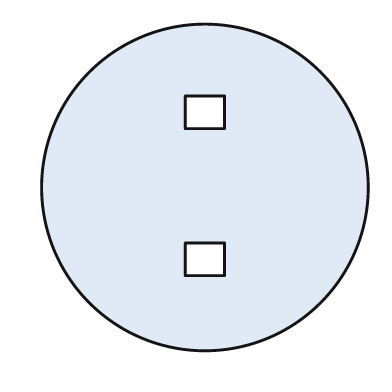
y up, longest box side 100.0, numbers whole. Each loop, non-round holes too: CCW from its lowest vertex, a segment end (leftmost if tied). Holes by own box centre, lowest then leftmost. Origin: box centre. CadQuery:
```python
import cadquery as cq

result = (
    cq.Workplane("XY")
    .moveTo(0.0, 0.0)
    .circle(50.0)
    .moveTo(-6.0, -27.0)
    .lineTo(6.0, -27.0)
    .lineTo(6.0, -17.0)
    .lineTo(-6.0, -17.0)
    .close()
    .moveTo(-6.0, 18.0)
    .lineTo(6.0, 18.0)
    .lineTo(6.0, 28.0)
    .lineTo(-6.0, 28.0)
    .close()
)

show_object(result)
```